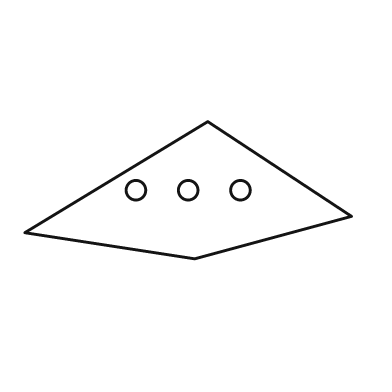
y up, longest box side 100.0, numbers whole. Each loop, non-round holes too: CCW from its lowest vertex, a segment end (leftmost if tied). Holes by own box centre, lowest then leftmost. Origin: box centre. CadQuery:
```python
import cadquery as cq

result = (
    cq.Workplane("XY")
    .moveTo(2.0, -21.0)
    .lineTo(50.0, -8.0)
    .lineTo(6.0, 21.0)
    .lineTo(-50.0, -13.0)
    .close()
    .moveTo(-16.0, 0.0)
    .circle(3.0)
    .moveTo(0.0, 0.0)
    .circle(3.0)
    .moveTo(16.0, 0.0)
    .circle(3.0)
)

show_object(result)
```